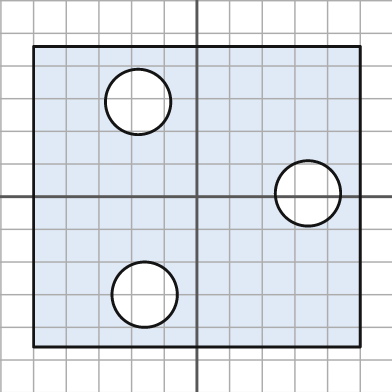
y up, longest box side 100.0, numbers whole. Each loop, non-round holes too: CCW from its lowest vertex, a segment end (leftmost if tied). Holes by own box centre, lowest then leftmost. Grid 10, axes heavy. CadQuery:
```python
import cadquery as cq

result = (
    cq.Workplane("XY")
    .moveTo(-50.0, -46.0)
    .lineTo(50.0, -46.0)
    .lineTo(50.0, 46.0)
    .lineTo(-50.0, 46.0)
    .close()
    .moveTo(-16.0, -30.0)
    .circle(10.0)
    .moveTo(34.0, 1.0)
    .circle(10.0)
    .moveTo(-18.0, 29.0)
    .circle(10.0)
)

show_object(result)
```